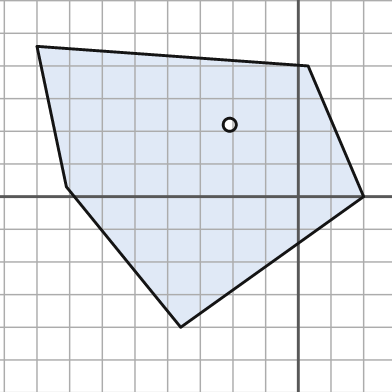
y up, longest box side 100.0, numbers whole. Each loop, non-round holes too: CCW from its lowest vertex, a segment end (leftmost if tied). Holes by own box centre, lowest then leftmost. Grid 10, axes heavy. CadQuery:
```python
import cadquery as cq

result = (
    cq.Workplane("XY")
    .moveTo(-36.0, -40.0)
    .lineTo(20.0, 0.0)
    .lineTo(3.0, 40.0)
    .lineTo(-80.0, 46.0)
    .lineTo(-71.0, 3.0)
    .close()
    .moveTo(-21.0, 22.0)
    .circle(2.0)
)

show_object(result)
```